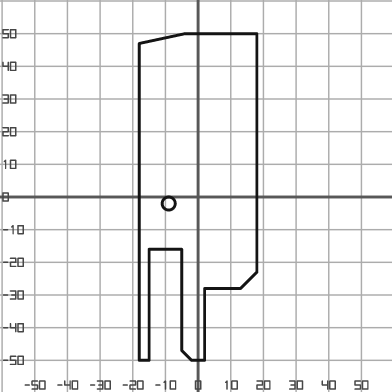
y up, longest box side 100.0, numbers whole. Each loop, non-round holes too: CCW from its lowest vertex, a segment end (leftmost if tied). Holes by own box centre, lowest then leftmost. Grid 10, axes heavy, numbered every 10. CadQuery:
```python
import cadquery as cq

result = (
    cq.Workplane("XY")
    .moveTo(-18.0, -50.0)
    .lineTo(-15.0, -50.0)
    .lineTo(-15.0, -16.0)
    .lineTo(-5.0, -16.0)
    .lineTo(-5.0, -47.0)
    .lineTo(-2.0, -50.0)
    .lineTo(2.0, -50.0)
    .lineTo(2.0, -28.0)
    .lineTo(13.0, -28.0)
    .lineTo(18.0, -23.0)
    .lineTo(18.0, 50.0)
    .lineTo(-4.0, 50.0)
    .lineTo(-18.0, 47.0)
    .close()
    .moveTo(-9.0, -2.0)
    .circle(2.0)
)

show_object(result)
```